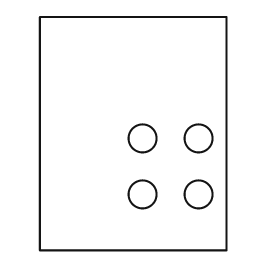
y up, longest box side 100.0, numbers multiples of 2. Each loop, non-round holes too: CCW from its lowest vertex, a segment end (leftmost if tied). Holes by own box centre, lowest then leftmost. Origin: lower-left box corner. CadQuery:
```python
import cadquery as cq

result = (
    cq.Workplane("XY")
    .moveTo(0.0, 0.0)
    .lineTo(80.0, 0.0)
    .lineTo(80.0, 100.0)
    .lineTo(0.0, 100.0)
    .close()
    .moveTo(44.0, 24.0)
    .circle(6.0)
    .moveTo(68.0, 24.0)
    .circle(6.0)
    .moveTo(44.0, 48.0)
    .circle(6.0)
    .moveTo(68.0, 48.0)
    .circle(6.0)
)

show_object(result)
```